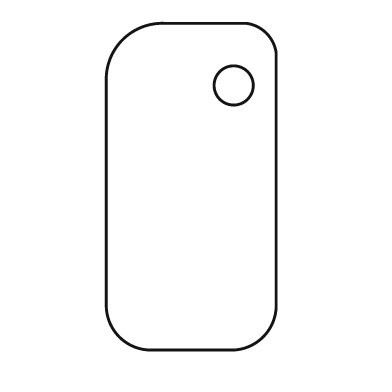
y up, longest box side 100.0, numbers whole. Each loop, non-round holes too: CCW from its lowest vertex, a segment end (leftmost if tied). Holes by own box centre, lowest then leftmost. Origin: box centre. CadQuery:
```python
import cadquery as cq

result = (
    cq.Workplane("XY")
    .moveTo(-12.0, -50.0)
    .lineTo(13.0, -50.0)
    .threePointArc((22.0, -46.0), (26.0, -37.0))
    .lineTo(26.0, 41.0)
    .threePointArc((23.0, 47.0), (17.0, 50.0))
    .lineTo(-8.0, 50.0)
    .threePointArc((-21.0, 45.0), (-26.0, 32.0))
    .lineTo(-26.0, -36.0)
    .threePointArc((-22.0, -46.0), (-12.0, -50.0))
    .close()
    .moveTo(13.0, 31.0)
    .circle(6.0)
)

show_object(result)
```